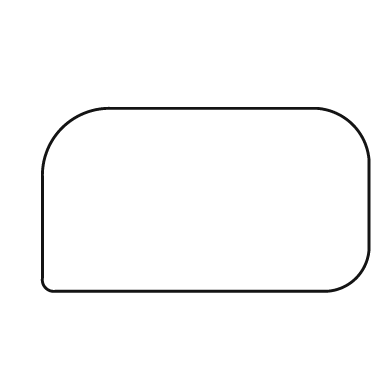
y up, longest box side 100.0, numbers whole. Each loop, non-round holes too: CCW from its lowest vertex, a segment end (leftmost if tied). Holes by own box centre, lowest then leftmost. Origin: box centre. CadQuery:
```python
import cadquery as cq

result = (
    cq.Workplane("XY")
    .moveTo(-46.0, -28.0)
    .lineTo(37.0, -28.0)
    .threePointArc((46.0, -24.0), (50.0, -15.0))
    .lineTo(50.0, 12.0)
    .threePointArc((45.0, 23.0), (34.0, 28.0))
    .lineTo(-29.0, 28.0)
    .threePointArc((-44.0, 22.0), (-50.0, 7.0))
    .lineTo(-50.0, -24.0)
    .threePointArc((-49.0, -27.0), (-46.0, -28.0))
    .close()
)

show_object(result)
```